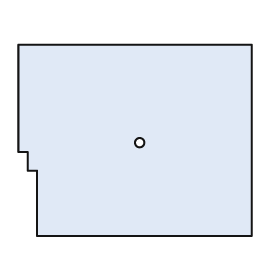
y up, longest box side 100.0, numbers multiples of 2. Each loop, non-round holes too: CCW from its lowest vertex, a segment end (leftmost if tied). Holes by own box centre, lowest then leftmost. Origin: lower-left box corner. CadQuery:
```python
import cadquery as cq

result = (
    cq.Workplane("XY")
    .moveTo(8.0, 0.0)
    .lineTo(100.0, 0.0)
    .lineTo(100.0, 82.0)
    .lineTo(0.0, 82.0)
    .lineTo(0.0, 36.0)
    .lineTo(4.0, 36.0)
    .lineTo(4.0, 28.0)
    .lineTo(8.0, 28.0)
    .close()
    .moveTo(52.0, 40.0)
    .circle(2.0)
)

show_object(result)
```